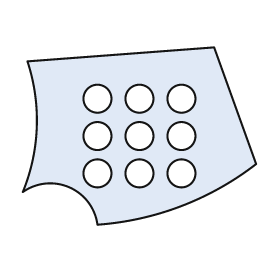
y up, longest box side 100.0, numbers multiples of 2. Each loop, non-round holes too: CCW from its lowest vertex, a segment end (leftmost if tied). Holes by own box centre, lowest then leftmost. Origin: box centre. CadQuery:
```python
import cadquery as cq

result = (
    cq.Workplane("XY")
    .moveTo(-18.0, -38.0)
    .threePointArc((18.0, -30.0), (50.0, -12.0))
    .lineTo(32.0, 38.0)
    .lineTo(-48.0, 32.0)
    .threePointArc((-44.0, 4.0), (-50.0, -24.0))
    .threePointArc((-30.0, -22.0), (-18.0, -38.0))
    .close()
    .moveTo(-18.0, -16.0)
    .circle(6.0)
    .moveTo(0.0, -16.0)
    .circle(6.0)
    .moveTo(18.0, -16.0)
    .circle(6.0)
    .moveTo(-18.0, 0.0)
    .circle(6.0)
    .moveTo(0.0, 0.0)
    .circle(6.0)
    .moveTo(18.0, 0.0)
    .circle(6.0)
    .moveTo(-18.0, 16.0)
    .circle(6.0)
    .moveTo(0.0, 16.0)
    .circle(6.0)
    .moveTo(18.0, 16.0)
    .circle(6.0)
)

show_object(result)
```